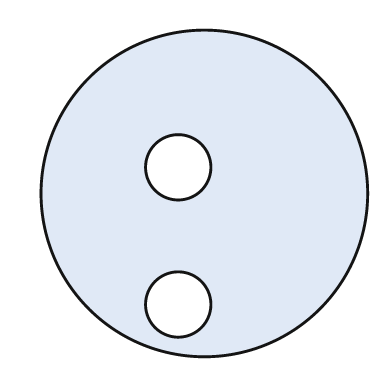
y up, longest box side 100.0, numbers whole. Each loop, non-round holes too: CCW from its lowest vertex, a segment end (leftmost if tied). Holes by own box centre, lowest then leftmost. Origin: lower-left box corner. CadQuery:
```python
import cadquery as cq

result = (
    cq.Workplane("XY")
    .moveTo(50.0, 50.0)
    .circle(50.0)
    .moveTo(42.0, 16.0)
    .circle(10.0)
    .moveTo(42.0, 58.0)
    .circle(10.0)
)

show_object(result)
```